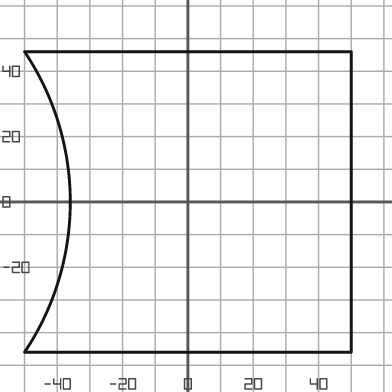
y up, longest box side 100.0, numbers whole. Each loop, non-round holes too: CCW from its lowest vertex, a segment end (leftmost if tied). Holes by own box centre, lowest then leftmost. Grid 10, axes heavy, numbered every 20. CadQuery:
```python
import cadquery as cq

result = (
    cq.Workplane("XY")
    .moveTo(-50.0, -46.0)
    .lineTo(50.0, -46.0)
    .lineTo(50.0, 46.0)
    .lineTo(-50.0, 46.0)
    .threePointArc((-36.0, 0.0), (-50.0, -46.0))
    .close()
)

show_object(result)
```